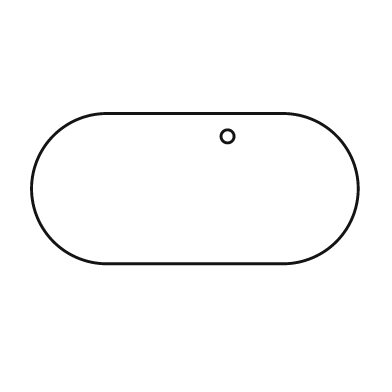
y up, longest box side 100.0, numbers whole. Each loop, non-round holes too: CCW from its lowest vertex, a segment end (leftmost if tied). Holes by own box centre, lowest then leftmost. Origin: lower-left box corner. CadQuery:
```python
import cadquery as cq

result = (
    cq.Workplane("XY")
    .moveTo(23.0, 0.0)
    .lineTo(77.0, 0.0)
    .threePointArc((100.0, 23.0), (77.0, 46.0))
    .lineTo(23.0, 46.0)
    .threePointArc((0.0, 23.0), (23.0, 0.0))
    .close()
    .moveTo(60.0, 39.0)
    .circle(2.0)
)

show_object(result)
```